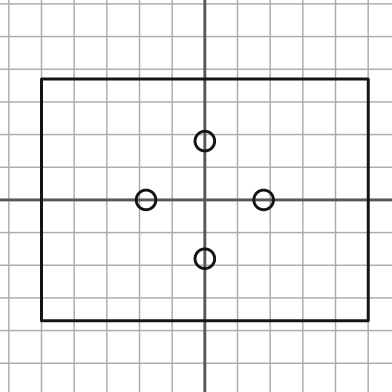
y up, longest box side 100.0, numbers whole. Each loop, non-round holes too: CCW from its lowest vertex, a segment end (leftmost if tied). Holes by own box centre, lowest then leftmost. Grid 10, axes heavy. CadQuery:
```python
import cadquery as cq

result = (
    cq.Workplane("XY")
    .moveTo(-50.0, -37.0)
    .lineTo(50.0, -37.0)
    .lineTo(50.0, 37.0)
    .lineTo(-50.0, 37.0)
    .close()
    .moveTo(0.0, -18.0)
    .circle(3.0)
    .moveTo(-18.0, 0.0)
    .circle(3.0)
    .moveTo(18.0, 0.0)
    .circle(3.0)
    .moveTo(0.0, 18.0)
    .circle(3.0)
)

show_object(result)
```